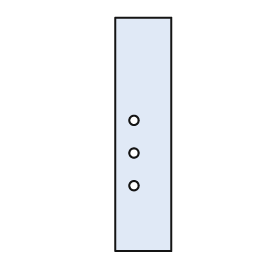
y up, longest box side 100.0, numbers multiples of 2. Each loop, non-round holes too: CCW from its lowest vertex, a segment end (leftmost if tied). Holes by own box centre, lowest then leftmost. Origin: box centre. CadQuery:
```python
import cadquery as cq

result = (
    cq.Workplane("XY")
    .moveTo(-12.0, -50.0)
    .lineTo(12.0, -50.0)
    .lineTo(12.0, 50.0)
    .lineTo(-12.0, 50.0)
    .close()
    .moveTo(-4.0, -22.0)
    .circle(2.0)
    .moveTo(-4.0, -8.0)
    .circle(2.0)
    .moveTo(-4.0, 6.0)
    .circle(2.0)
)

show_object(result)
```